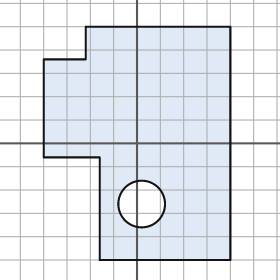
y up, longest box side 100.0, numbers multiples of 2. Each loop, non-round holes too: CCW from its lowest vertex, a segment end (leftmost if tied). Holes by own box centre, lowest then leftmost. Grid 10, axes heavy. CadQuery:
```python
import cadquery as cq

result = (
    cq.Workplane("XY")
    .moveTo(-16.0, -50.0)
    .lineTo(40.0, -50.0)
    .lineTo(40.0, 50.0)
    .lineTo(-22.0, 50.0)
    .lineTo(-22.0, 36.0)
    .lineTo(-40.0, 36.0)
    .lineTo(-40.0, -6.0)
    .lineTo(-16.0, -6.0)
    .close()
    .moveTo(2.0, -26.0)
    .circle(10.0)
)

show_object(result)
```